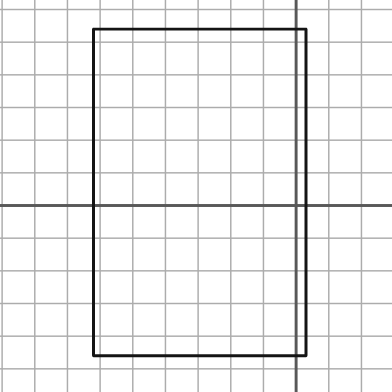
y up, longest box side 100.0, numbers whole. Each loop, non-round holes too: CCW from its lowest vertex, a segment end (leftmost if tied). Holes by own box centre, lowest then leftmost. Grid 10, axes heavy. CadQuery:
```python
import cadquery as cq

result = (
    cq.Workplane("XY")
    .moveTo(-62.0, -46.0)
    .lineTo(3.0, -46.0)
    .lineTo(3.0, 54.0)
    .lineTo(-62.0, 54.0)
    .close()
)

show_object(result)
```